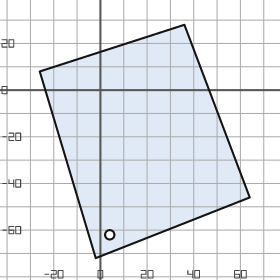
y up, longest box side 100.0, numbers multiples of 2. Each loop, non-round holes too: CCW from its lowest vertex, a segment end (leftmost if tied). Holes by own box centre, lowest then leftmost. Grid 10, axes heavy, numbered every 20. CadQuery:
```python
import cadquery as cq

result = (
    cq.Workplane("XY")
    .moveTo(-2.0, -72.0)
    .lineTo(64.0, -46.0)
    .lineTo(36.0, 28.0)
    .lineTo(-26.0, 8.0)
    .close()
    .moveTo(4.0, -62.0)
    .circle(2.0)
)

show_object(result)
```